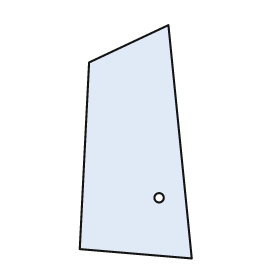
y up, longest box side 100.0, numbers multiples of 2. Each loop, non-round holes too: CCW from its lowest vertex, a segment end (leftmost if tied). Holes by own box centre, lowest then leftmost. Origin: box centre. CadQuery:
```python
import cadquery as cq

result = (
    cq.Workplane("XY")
    .moveTo(24.0, -50.0)
    .lineTo(14.0, 50.0)
    .lineTo(-20.0, 34.0)
    .lineTo(-24.0, -46.0)
    .close()
    .moveTo(10.0, -24.0)
    .circle(2.0)
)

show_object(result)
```